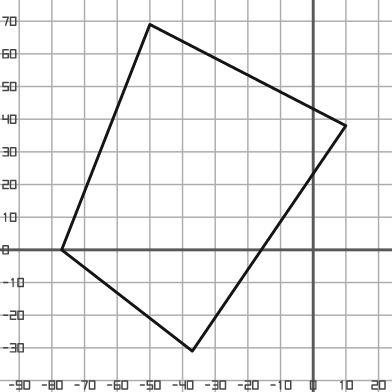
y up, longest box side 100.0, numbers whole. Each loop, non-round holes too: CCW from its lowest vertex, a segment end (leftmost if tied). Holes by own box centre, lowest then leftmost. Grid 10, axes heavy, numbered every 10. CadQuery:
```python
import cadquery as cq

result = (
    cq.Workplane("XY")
    .moveTo(-37.0, -31.0)
    .lineTo(10.0, 38.0)
    .lineTo(-50.0, 69.0)
    .lineTo(-77.0, 0.0)
    .close()
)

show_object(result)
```